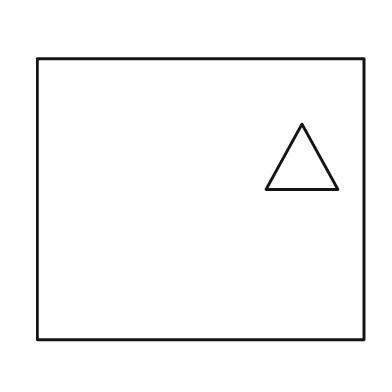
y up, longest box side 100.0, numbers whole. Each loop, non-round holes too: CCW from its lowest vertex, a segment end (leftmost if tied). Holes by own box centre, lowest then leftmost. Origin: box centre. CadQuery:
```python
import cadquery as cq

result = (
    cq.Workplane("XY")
    .moveTo(-50.0, -43.0)
    .lineTo(50.0, -43.0)
    .lineTo(50.0, 43.0)
    .lineTo(-50.0, 43.0)
    .close()
    .moveTo(20.0, 3.0)
    .lineTo(42.0, 3.0)
    .lineTo(31.0, 23.0)
    .close()
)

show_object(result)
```